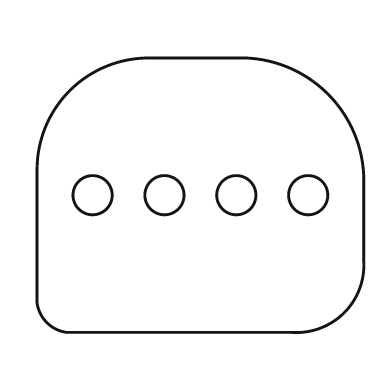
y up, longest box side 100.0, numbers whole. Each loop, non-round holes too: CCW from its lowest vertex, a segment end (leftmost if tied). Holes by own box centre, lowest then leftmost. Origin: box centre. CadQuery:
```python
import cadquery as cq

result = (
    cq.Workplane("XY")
    .moveTo(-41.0, -42.0)
    .lineTo(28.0, -42.0)
    .threePointArc((44.0, -36.0), (50.0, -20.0))
    .lineTo(50.0, 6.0)
    .threePointArc((39.0, 31.0), (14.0, 42.0))
    .lineTo(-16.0, 42.0)
    .threePointArc((-40.0, 32.0), (-50.0, 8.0))
    .lineTo(-50.0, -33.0)
    .threePointArc((-47.0, -39.0), (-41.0, -42.0))
    .close()
    .moveTo(-33.0, 0.0)
    .circle(6.0)
    .moveTo(-11.0, 0.0)
    .circle(6.0)
    .moveTo(11.0, 0.0)
    .circle(6.0)
    .moveTo(33.0, 0.0)
    .circle(6.0)
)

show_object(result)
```